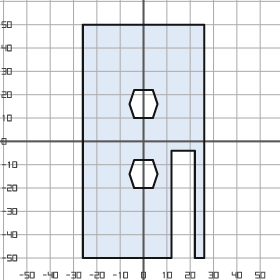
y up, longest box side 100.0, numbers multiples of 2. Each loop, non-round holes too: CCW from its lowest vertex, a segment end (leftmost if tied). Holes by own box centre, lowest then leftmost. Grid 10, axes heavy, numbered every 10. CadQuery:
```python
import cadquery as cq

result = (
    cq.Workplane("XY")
    .moveTo(-26.0, -50.0)
    .lineTo(12.0, -50.0)
    .lineTo(12.0, -4.0)
    .lineTo(22.0, -4.0)
    .lineTo(22.0, -50.0)
    .lineTo(26.0, -50.0)
    .lineTo(26.0, 50.0)
    .lineTo(-26.0, 50.0)
    .close()
    .moveTo(-4.0, -20.0)
    .lineTo(4.0, -20.0)
    .lineTo(6.0, -14.0)
    .lineTo(4.0, -8.0)
    .lineTo(-4.0, -8.0)
    .lineTo(-6.0, -14.0)
    .close()
    .moveTo(-4.0, 10.0)
    .lineTo(4.0, 10.0)
    .lineTo(6.0, 16.0)
    .lineTo(4.0, 22.0)
    .lineTo(-4.0, 22.0)
    .lineTo(-6.0, 16.0)
    .close()
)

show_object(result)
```